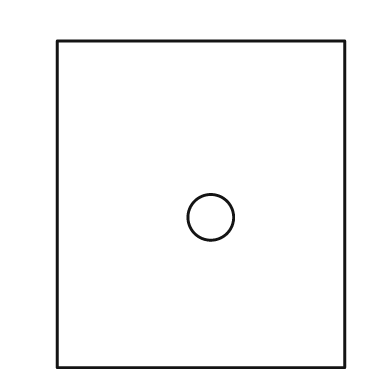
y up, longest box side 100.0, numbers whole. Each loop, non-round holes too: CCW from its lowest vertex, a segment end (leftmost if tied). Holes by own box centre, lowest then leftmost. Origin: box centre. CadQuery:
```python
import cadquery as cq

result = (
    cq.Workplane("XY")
    .moveTo(-44.0, -50.0)
    .lineTo(44.0, -50.0)
    .lineTo(44.0, 50.0)
    .lineTo(-44.0, 50.0)
    .close()
    .moveTo(3.0, -4.0)
    .circle(7.0)
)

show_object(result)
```